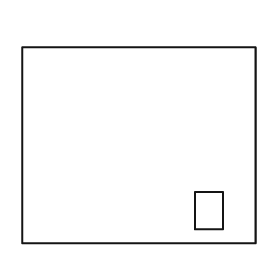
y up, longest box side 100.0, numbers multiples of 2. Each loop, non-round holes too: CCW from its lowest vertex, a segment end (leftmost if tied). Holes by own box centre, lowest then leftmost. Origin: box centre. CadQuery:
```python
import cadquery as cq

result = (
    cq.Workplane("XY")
    .moveTo(-50.0, -42.0)
    .lineTo(50.0, -42.0)
    .lineTo(50.0, 42.0)
    .lineTo(-50.0, 42.0)
    .close()
    .moveTo(24.0, -36.0)
    .lineTo(36.0, -36.0)
    .lineTo(36.0, -20.0)
    .lineTo(24.0, -20.0)
    .close()
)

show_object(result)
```